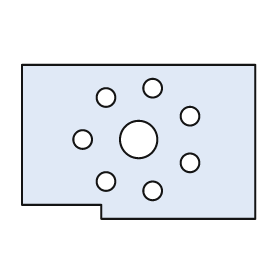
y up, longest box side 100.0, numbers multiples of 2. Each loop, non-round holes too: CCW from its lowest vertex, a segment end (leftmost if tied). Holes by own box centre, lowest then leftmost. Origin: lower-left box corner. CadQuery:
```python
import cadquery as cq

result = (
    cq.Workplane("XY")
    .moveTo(34.0, 0.0)
    .lineTo(100.0, 0.0)
    .lineTo(100.0, 66.0)
    .lineTo(0.0, 66.0)
    .lineTo(0.0, 6.0)
    .lineTo(34.0, 6.0)
    .close()
    .moveTo(56.0, 12.0)
    .circle(4.0)
    .moveTo(36.0, 16.0)
    .circle(4.0)
    .moveTo(72.0, 24.0)
    .circle(4.0)
    .moveTo(26.0, 34.0)
    .circle(4.0)
    .moveTo(50.0, 34.0)
    .circle(8.0)
    .moveTo(72.0, 44.0)
    .circle(4.0)
    .moveTo(36.0, 52.0)
    .circle(4.0)
    .moveTo(56.0, 56.0)
    .circle(4.0)
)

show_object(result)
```